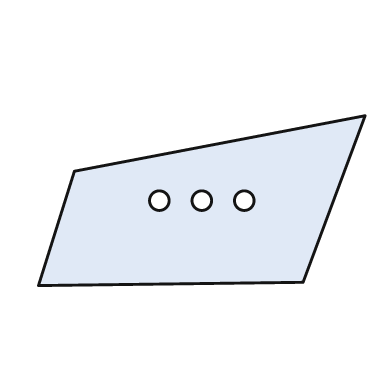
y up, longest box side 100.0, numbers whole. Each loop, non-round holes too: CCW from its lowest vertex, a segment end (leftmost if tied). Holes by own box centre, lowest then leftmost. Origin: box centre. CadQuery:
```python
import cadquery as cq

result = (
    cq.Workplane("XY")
    .moveTo(-50.0, -26.0)
    .lineTo(31.0, -25.0)
    .lineTo(50.0, 26.0)
    .lineTo(-39.0, 9.0)
    .close()
    .moveTo(-13.0, 0.0)
    .circle(3.0)
    .moveTo(0.0, 0.0)
    .circle(3.0)
    .moveTo(13.0, 0.0)
    .circle(3.0)
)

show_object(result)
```